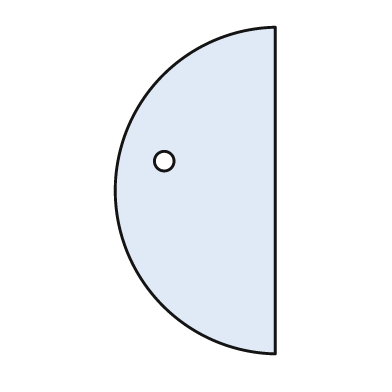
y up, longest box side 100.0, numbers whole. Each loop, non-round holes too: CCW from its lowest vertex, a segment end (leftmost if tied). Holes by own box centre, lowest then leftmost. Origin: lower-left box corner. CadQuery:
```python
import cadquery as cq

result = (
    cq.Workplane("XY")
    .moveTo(49.0, 0.0)
    .lineTo(49.0, 100.0)
    .threePointArc((0.0, 50.0), (49.0, 0.0))
    .close()
    .moveTo(15.0, 59.0)
    .circle(3.0)
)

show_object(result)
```